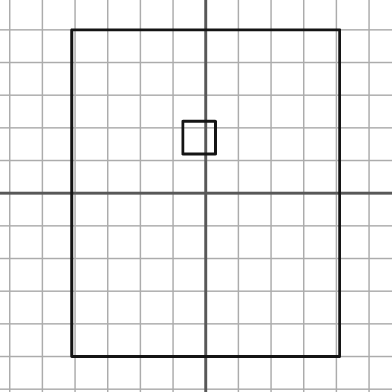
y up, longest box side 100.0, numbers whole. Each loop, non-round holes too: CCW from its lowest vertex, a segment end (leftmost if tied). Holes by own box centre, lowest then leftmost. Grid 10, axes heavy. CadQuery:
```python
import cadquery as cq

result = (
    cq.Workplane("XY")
    .moveTo(-41.0, -50.0)
    .lineTo(41.0, -50.0)
    .lineTo(41.0, 50.0)
    .lineTo(-41.0, 50.0)
    .close()
    .moveTo(-7.0, 12.0)
    .lineTo(3.0, 12.0)
    .lineTo(3.0, 22.0)
    .lineTo(-7.0, 22.0)
    .close()
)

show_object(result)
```